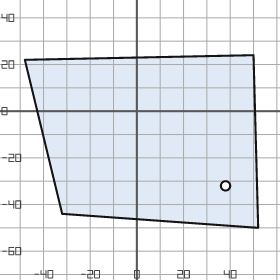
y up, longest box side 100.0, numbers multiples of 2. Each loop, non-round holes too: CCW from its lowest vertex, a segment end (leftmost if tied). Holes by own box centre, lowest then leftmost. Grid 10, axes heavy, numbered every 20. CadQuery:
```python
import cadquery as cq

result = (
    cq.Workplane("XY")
    .moveTo(52.0, -50.0)
    .lineTo(50.0, 24.0)
    .lineTo(-48.0, 22.0)
    .lineTo(-32.0, -44.0)
    .close()
    .moveTo(38.0, -32.0)
    .circle(2.0)
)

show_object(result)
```